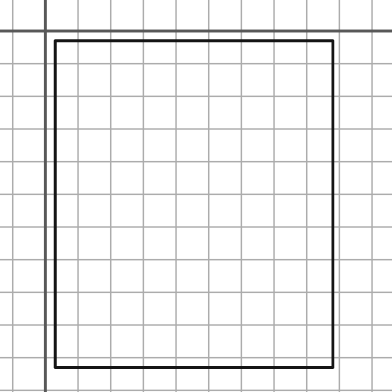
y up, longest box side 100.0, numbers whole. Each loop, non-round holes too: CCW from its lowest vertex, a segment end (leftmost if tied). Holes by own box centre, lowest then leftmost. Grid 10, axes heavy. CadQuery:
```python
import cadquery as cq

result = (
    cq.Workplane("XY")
    .moveTo(3.0, -103.0)
    .lineTo(88.0, -103.0)
    .lineTo(88.0, -3.0)
    .lineTo(3.0, -3.0)
    .close()
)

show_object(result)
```